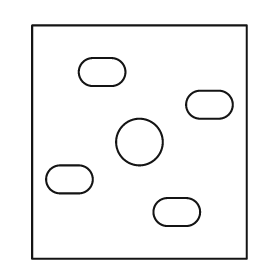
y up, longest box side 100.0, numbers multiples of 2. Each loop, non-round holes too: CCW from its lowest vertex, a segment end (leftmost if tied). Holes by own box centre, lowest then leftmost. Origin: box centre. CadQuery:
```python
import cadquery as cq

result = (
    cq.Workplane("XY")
    .moveTo(-46.0, -50.0)
    .lineTo(46.0, -50.0)
    .lineTo(46.0, 50.0)
    .lineTo(-46.0, 50.0)
    .close()
    .moveTo(12.0, -36.0)
    .lineTo(20.0, -36.0)
    .threePointArc((26.0, -30.0), (20.0, -24.0))
    .lineTo(12.0, -24.0)
    .threePointArc((6.0, -30.0), (12.0, -36.0))
    .close()
    .moveTo(-34.0, -22.0)
    .lineTo(-26.0, -22.0)
    .threePointArc((-20.0, -16.0), (-26.0, -10.0))
    .lineTo(-34.0, -10.0)
    .threePointArc((-40.0, -16.0), (-34.0, -22.0))
    .close()
    .moveTo(0.0, 0.0)
    .circle(10.0)
    .moveTo(26.0, 10.0)
    .lineTo(34.0, 10.0)
    .threePointArc((40.0, 16.0), (34.0, 22.0))
    .lineTo(26.0, 22.0)
    .threePointArc((20.0, 16.0), (26.0, 10.0))
    .close()
    .moveTo(-20.0, 24.0)
    .lineTo(-12.0, 24.0)
    .threePointArc((-6.0, 30.0), (-12.0, 36.0))
    .lineTo(-20.0, 36.0)
    .threePointArc((-26.0, 30.0), (-20.0, 24.0))
    .close()
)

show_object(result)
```